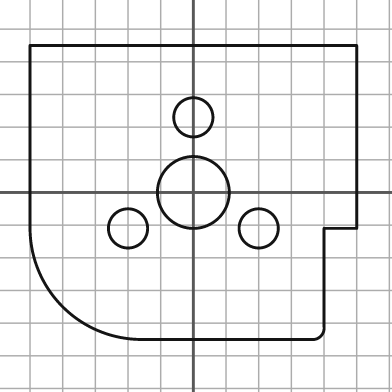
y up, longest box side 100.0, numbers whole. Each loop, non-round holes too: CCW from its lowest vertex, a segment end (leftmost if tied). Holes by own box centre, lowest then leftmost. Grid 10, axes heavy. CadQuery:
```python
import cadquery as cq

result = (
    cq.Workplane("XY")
    .moveTo(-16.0, -45.0)
    .lineTo(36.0, -45.0)
    .threePointArc((39.0, -44.0), (40.0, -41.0))
    .lineTo(40.0, -11.0)
    .lineTo(50.0, -11.0)
    .lineTo(50.0, 45.0)
    .lineTo(-50.0, 45.0)
    .lineTo(-50.0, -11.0)
    .threePointArc((-40.0, -35.0), (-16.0, -45.0))
    .close()
    .moveTo(-20.0, -11.0)
    .circle(6.0)
    .moveTo(20.0, -11.0)
    .circle(6.0)
    .moveTo(0.0, 0.0)
    .circle(11.0)
    .moveTo(0.0, 23.0)
    .circle(6.0)
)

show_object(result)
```